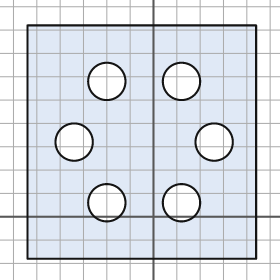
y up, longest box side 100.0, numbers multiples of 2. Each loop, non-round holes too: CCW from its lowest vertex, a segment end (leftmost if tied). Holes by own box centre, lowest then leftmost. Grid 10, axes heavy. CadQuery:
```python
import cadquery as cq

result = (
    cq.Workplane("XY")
    .moveTo(-54.0, -18.0)
    .lineTo(44.0, -18.0)
    .lineTo(44.0, 82.0)
    .lineTo(-54.0, 82.0)
    .close()
    .moveTo(-20.0, 6.0)
    .circle(8.0)
    .moveTo(12.0, 6.0)
    .circle(8.0)
    .moveTo(-34.0, 32.0)
    .circle(8.0)
    .moveTo(26.0, 32.0)
    .circle(8.0)
    .moveTo(-20.0, 58.0)
    .circle(8.0)
    .moveTo(12.0, 58.0)
    .circle(8.0)
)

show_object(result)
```